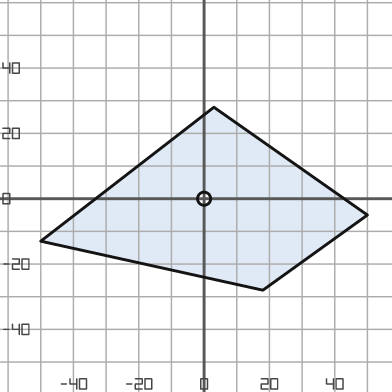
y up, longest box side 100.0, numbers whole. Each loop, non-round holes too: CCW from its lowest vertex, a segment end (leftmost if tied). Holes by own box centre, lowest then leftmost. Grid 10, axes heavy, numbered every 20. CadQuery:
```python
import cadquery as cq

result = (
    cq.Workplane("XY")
    .moveTo(18.0, -28.0)
    .lineTo(50.0, -5.0)
    .lineTo(3.0, 28.0)
    .lineTo(-50.0, -13.0)
    .close()
    .moveTo(0.0, 0.0)
    .circle(2.0)
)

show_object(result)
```